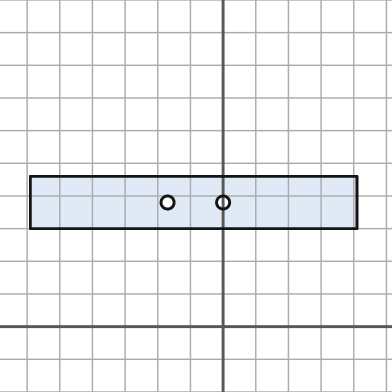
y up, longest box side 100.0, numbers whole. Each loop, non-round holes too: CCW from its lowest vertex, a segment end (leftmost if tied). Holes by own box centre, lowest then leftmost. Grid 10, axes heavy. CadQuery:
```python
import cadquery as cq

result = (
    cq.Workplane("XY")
    .moveTo(-59.0, 30.0)
    .lineTo(41.0, 30.0)
    .lineTo(41.0, 46.0)
    .lineTo(-59.0, 46.0)
    .close()
    .moveTo(-17.0, 38.0)
    .circle(2.0)
    .moveTo(0.0, 38.0)
    .circle(2.0)
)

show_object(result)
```